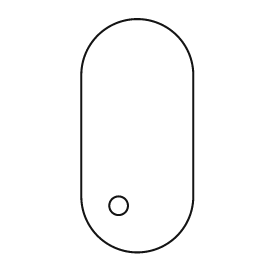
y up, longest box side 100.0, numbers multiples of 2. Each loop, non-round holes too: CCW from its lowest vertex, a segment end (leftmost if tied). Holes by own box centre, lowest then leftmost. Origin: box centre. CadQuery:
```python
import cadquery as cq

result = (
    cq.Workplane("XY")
    .moveTo(-24.0, -26.0)
    .threePointArc((0.0, -50.0), (24.0, -26.0))
    .lineTo(24.0, 26.0)
    .threePointArc((0.0, 50.0), (-24.0, 26.0))
    .close()
    .moveTo(-8.0, -30.0)
    .circle(4.0)
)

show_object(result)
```